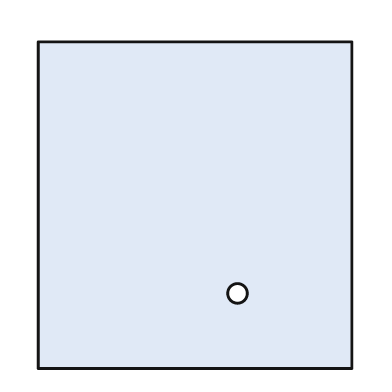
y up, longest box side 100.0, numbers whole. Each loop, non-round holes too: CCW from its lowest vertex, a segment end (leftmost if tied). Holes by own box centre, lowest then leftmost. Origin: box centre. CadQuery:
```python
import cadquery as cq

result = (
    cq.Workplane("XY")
    .moveTo(-48.0, -50.0)
    .lineTo(48.0, -50.0)
    .lineTo(48.0, 50.0)
    .lineTo(-48.0, 50.0)
    .close()
    .moveTo(13.0, -27.0)
    .circle(3.0)
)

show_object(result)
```